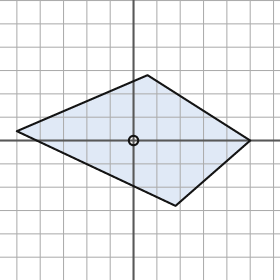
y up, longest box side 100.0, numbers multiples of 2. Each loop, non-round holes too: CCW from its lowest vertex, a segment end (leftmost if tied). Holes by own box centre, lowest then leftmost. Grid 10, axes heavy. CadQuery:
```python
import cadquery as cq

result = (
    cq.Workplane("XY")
    .moveTo(18.0, -28.0)
    .lineTo(50.0, 0.0)
    .lineTo(6.0, 28.0)
    .lineTo(-50.0, 4.0)
    .close()
    .moveTo(0.0, 0.0)
    .circle(2.0)
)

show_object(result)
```